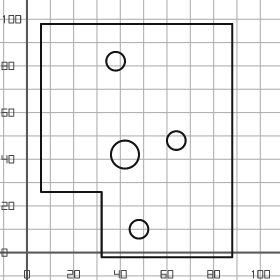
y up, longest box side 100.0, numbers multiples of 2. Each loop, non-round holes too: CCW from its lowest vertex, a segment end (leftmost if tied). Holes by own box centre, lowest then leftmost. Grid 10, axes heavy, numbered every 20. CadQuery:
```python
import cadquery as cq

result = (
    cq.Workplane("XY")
    .moveTo(32.0, -2.0)
    .lineTo(88.0, -2.0)
    .lineTo(88.0, 98.0)
    .lineTo(6.0, 98.0)
    .lineTo(6.0, 26.0)
    .lineTo(32.0, 26.0)
    .close()
    .moveTo(48.0, 10.0)
    .circle(4.0)
    .moveTo(42.0, 42.0)
    .circle(6.0)
    .moveTo(64.0, 48.0)
    .circle(4.0)
    .moveTo(38.0, 82.0)
    .circle(4.0)
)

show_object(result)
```